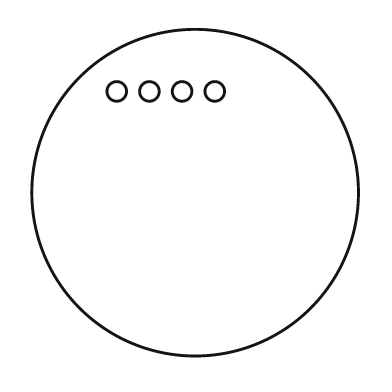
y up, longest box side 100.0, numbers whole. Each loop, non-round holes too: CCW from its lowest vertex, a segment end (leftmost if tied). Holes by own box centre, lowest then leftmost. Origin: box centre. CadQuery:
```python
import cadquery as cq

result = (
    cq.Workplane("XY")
    .moveTo(0.0, 0.0)
    .circle(50.0)
    .moveTo(-24.0, 31.0)
    .circle(3.0)
    .moveTo(-14.0, 31.0)
    .circle(3.0)
    .moveTo(-4.0, 31.0)
    .circle(3.0)
    .moveTo(6.0, 31.0)
    .circle(3.0)
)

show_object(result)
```